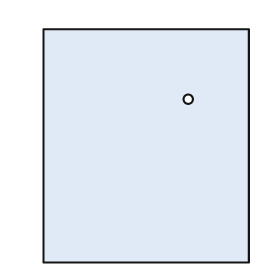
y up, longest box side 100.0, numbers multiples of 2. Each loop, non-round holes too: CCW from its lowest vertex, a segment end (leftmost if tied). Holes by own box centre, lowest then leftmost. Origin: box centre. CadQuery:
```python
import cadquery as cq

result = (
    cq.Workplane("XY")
    .moveTo(-44.0, -50.0)
    .lineTo(44.0, -50.0)
    .lineTo(44.0, 50.0)
    .lineTo(-44.0, 50.0)
    .close()
    .moveTo(18.0, 20.0)
    .circle(2.0)
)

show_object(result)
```